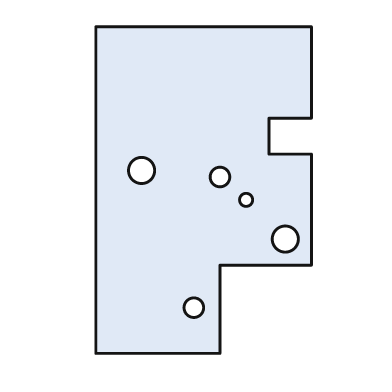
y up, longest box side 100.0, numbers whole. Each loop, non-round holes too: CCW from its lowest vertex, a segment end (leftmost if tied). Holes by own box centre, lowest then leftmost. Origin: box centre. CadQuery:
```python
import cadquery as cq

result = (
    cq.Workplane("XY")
    .moveTo(-33.0, -50.0)
    .lineTo(5.0, -50.0)
    .lineTo(5.0, -23.0)
    .lineTo(33.0, -23.0)
    .lineTo(33.0, 11.0)
    .lineTo(20.0, 11.0)
    .lineTo(20.0, 22.0)
    .lineTo(33.0, 22.0)
    .lineTo(33.0, 50.0)
    .lineTo(-33.0, 50.0)
    .close()
    .moveTo(-3.0, -36.0)
    .circle(3.0)
    .moveTo(25.0, -15.0)
    .circle(4.0)
    .moveTo(13.0, -3.0)
    .circle(2.0)
    .moveTo(5.0, 4.0)
    .circle(3.0)
    .moveTo(-19.0, 6.0)
    .circle(4.0)
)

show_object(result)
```